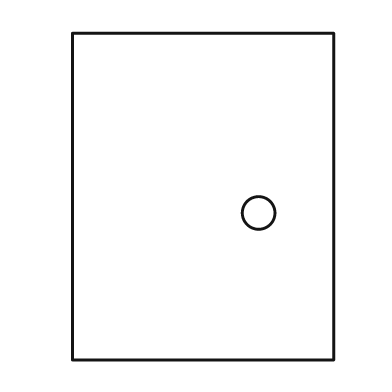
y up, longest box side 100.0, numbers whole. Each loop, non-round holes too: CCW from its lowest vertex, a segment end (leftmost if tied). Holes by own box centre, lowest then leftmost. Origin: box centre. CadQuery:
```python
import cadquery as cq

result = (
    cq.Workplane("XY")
    .moveTo(-40.0, -50.0)
    .lineTo(40.0, -50.0)
    .lineTo(40.0, 50.0)
    .lineTo(-40.0, 50.0)
    .close()
    .moveTo(17.0, -5.0)
    .circle(5.0)
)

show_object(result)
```